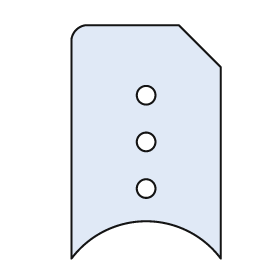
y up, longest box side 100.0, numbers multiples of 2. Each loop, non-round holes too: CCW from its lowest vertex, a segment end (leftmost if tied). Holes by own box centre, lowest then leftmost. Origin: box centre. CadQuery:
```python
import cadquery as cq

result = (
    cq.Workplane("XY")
    .moveTo(-32.0, -50.0)
    .threePointArc((0.0, -34.0), (32.0, -50.0))
    .lineTo(32.0, 32.0)
    .lineTo(14.0, 50.0)
    .lineTo(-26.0, 50.0)
    .threePointArc((-30.0, 48.0), (-32.0, 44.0))
    .close()
    .moveTo(0.0, -20.0)
    .circle(4.0)
    .moveTo(0.0, 0.0)
    .circle(4.0)
    .moveTo(0.0, 20.0)
    .circle(4.0)
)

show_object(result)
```